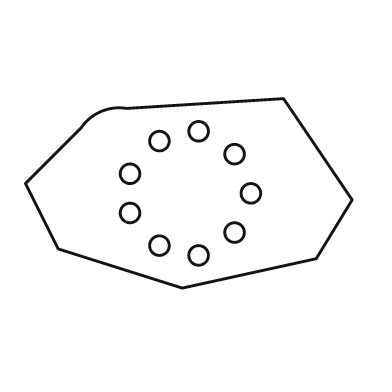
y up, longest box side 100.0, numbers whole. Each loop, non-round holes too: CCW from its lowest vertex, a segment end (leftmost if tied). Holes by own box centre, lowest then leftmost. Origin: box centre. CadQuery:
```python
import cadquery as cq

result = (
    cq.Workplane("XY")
    .moveTo(-2.0, -29.0)
    .lineTo(39.0, -20.0)
    .lineTo(50.0, -2.0)
    .lineTo(29.0, 29.0)
    .lineTo(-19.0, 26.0)
    .threePointArc((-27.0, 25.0), (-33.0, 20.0))
    .lineTo(-50.0, 3.0)
    .lineTo(-40.0, -17.0)
    .close()
    .moveTo(3.0, -19.0)
    .circle(3.0)
    .moveTo(-9.0, -16.0)
    .circle(3.0)
    .moveTo(14.0, -12.0)
    .circle(3.0)
    .moveTo(-18.0, -6.0)
    .circle(3.0)
    .moveTo(19.0, 0.0)
    .circle(3.0)
    .moveTo(-18.0, 6.0)
    .circle(3.0)
    .moveTo(14.0, 12.0)
    .circle(3.0)
    .moveTo(-9.0, 16.0)
    .circle(3.0)
    .moveTo(3.0, 19.0)
    .circle(3.0)
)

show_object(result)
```